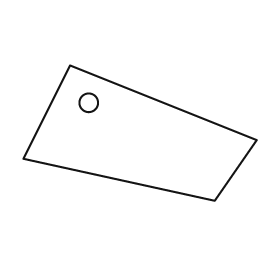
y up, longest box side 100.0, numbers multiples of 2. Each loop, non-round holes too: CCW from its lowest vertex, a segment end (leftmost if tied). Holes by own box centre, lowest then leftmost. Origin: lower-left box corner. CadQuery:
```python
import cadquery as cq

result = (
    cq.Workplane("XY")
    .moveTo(82.0, 0.0)
    .lineTo(100.0, 26.0)
    .lineTo(20.0, 58.0)
    .lineTo(0.0, 18.0)
    .close()
    .moveTo(28.0, 42.0)
    .circle(4.0)
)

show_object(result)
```